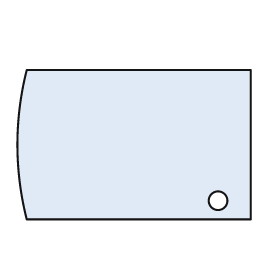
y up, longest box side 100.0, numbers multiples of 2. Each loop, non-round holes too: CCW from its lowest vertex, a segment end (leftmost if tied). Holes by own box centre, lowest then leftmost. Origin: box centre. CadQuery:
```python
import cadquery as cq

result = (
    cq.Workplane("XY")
    .moveTo(-46.0, -32.0)
    .lineTo(50.0, -32.0)
    .lineTo(50.0, 32.0)
    .lineTo(-46.0, 32.0)
    .threePointArc((-50.0, 0.0), (-46.0, -32.0))
    .close()
    .moveTo(36.0, -24.0)
    .circle(4.0)
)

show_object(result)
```